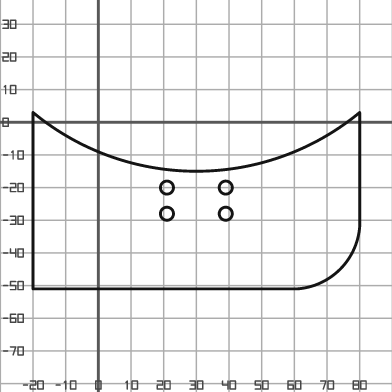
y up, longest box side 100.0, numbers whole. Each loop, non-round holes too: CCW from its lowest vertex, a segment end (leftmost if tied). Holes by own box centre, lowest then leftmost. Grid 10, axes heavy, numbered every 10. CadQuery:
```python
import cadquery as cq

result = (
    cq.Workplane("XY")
    .moveTo(-20.0, -51.0)
    .lineTo(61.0, -51.0)
    .threePointArc((74.0, -45.0), (80.0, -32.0))
    .lineTo(80.0, 3.0)
    .threePointArc((30.0, -15.0), (-20.0, 3.0))
    .close()
    .moveTo(21.0, -28.0)
    .circle(2.0)
    .moveTo(39.0, -28.0)
    .circle(2.0)
    .moveTo(21.0, -20.0)
    .circle(2.0)
    .moveTo(39.0, -20.0)
    .circle(2.0)
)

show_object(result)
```